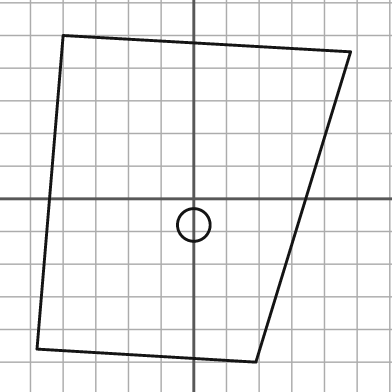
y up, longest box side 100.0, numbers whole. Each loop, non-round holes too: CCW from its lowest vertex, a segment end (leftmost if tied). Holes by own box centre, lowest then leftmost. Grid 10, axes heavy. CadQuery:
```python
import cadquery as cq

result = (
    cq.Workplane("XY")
    .moveTo(19.0, -50.0)
    .lineTo(48.0, 45.0)
    .lineTo(-40.0, 50.0)
    .lineTo(-48.0, -46.0)
    .close()
    .moveTo(0.0, -8.0)
    .circle(5.0)
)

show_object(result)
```